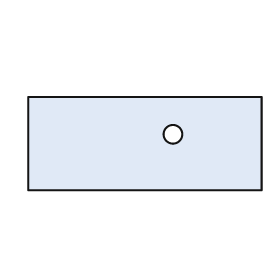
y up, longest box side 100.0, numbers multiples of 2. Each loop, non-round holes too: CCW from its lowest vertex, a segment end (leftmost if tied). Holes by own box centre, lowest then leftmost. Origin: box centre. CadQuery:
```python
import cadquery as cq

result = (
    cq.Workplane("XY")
    .moveTo(-50.0, -20.0)
    .lineTo(50.0, -20.0)
    .lineTo(50.0, 20.0)
    .lineTo(-50.0, 20.0)
    .close()
    .moveTo(12.0, 4.0)
    .circle(4.0)
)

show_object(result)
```